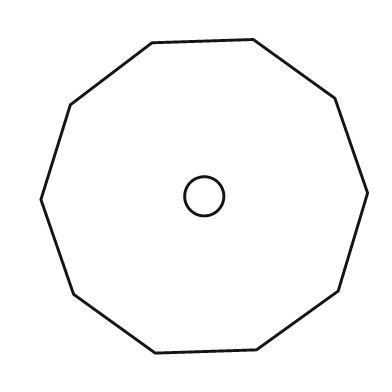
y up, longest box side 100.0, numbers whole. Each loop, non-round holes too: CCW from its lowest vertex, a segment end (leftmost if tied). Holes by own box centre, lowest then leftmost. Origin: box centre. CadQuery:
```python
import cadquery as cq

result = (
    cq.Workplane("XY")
    .moveTo(-15.0, -48.0)
    .lineTo(16.0, -47.0)
    .lineTo(41.0, -29.0)
    .lineTo(50.0, 1.0)
    .lineTo(40.0, 30.0)
    .lineTo(15.0, 48.0)
    .lineTo(-16.0, 47.0)
    .lineTo(-41.0, 28.0)
    .lineTo(-50.0, -1.0)
    .lineTo(-40.0, -30.0)
    .close()
    .moveTo(0.0, 0.0)
    .circle(6.0)
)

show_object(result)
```